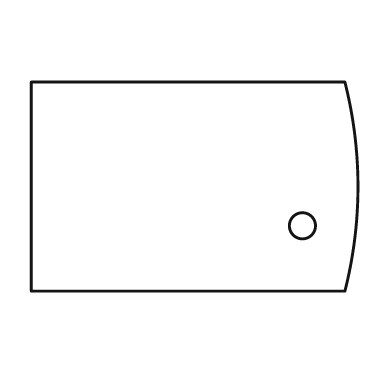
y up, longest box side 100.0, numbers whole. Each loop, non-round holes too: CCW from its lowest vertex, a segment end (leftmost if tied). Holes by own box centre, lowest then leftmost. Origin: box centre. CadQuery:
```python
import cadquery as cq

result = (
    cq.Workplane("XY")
    .moveTo(-50.0, -32.0)
    .lineTo(46.0, -32.0)
    .threePointArc((50.0, 0.0), (46.0, 32.0))
    .lineTo(-50.0, 32.0)
    .close()
    .moveTo(33.0, -12.0)
    .circle(4.0)
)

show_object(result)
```